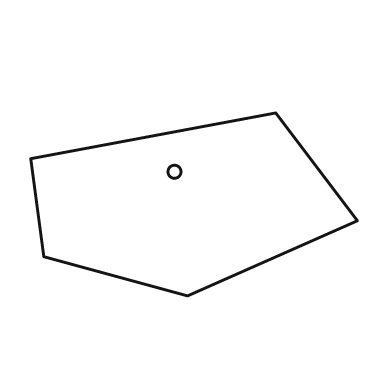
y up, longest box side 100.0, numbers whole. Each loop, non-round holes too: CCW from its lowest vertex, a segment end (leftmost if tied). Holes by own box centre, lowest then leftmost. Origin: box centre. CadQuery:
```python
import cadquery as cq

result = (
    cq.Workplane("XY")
    .moveTo(-2.0, -28.0)
    .lineTo(50.0, -5.0)
    .lineTo(25.0, 28.0)
    .lineTo(-50.0, 14.0)
    .lineTo(-46.0, -16.0)
    .close()
    .moveTo(-6.0, 10.0)
    .circle(2.0)
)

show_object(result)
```